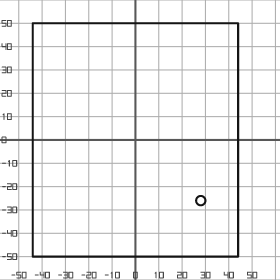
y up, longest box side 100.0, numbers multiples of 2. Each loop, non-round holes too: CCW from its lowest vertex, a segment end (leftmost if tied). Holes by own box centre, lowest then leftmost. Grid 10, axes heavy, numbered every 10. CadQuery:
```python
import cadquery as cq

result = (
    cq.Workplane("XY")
    .moveTo(-44.0, -50.0)
    .lineTo(44.0, -50.0)
    .lineTo(44.0, 50.0)
    .lineTo(-44.0, 50.0)
    .close()
    .moveTo(28.0, -26.0)
    .circle(2.0)
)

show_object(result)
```